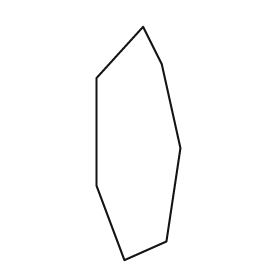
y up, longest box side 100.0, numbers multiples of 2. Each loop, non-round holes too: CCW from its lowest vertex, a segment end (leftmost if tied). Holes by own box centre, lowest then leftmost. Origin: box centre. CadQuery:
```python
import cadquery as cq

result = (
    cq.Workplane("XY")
    .moveTo(-6.0, -50.0)
    .lineTo(12.0, -42.0)
    .lineTo(18.0, -2.0)
    .lineTo(10.0, 34.0)
    .lineTo(2.0, 50.0)
    .lineTo(-18.0, 28.0)
    .lineTo(-18.0, -18.0)
    .close()
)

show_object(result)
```